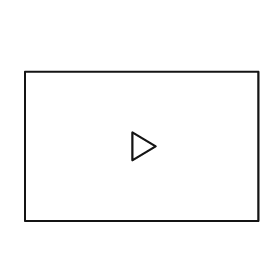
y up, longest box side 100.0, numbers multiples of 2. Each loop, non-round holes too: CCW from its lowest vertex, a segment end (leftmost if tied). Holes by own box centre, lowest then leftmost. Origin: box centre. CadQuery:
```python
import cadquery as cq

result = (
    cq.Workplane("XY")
    .moveTo(-50.0, -32.0)
    .lineTo(50.0, -32.0)
    .lineTo(50.0, 32.0)
    .lineTo(-50.0, 32.0)
    .close()
    .moveTo(-4.0, -6.0)
    .lineTo(6.0, 0.0)
    .lineTo(-4.0, 6.0)
    .close()
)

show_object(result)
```